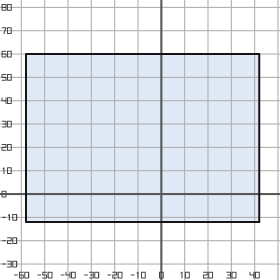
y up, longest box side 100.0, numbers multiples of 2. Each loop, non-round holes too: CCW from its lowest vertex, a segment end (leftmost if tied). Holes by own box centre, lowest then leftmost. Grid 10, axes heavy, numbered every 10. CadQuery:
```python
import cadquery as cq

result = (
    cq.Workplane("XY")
    .moveTo(-58.0, -12.0)
    .lineTo(42.0, -12.0)
    .lineTo(42.0, 60.0)
    .lineTo(-58.0, 60.0)
    .close()
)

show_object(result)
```